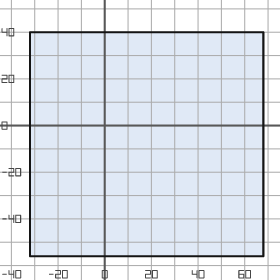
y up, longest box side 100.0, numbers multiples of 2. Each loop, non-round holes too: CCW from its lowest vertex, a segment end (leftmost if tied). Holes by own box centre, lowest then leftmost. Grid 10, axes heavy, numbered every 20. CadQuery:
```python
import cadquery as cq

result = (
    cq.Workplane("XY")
    .moveTo(-32.0, -56.0)
    .lineTo(68.0, -56.0)
    .lineTo(68.0, 40.0)
    .lineTo(-32.0, 40.0)
    .close()
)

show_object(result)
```